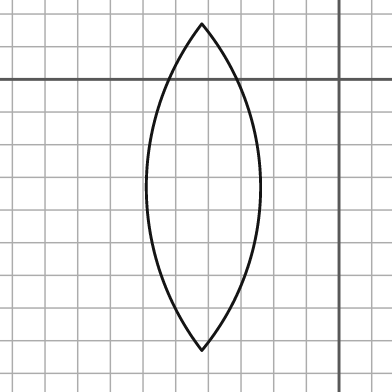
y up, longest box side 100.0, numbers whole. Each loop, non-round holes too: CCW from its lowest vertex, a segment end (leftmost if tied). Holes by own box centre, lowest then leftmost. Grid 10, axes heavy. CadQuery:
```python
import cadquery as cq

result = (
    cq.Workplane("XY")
    .moveTo(-42.0, -83.0)
    .threePointArc((-24.0, -33.0), (-42.0, 17.0))
    .threePointArc((-59.0, -33.0), (-42.0, -83.0))
    .close()
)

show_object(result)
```